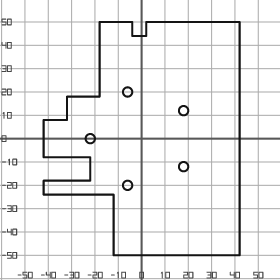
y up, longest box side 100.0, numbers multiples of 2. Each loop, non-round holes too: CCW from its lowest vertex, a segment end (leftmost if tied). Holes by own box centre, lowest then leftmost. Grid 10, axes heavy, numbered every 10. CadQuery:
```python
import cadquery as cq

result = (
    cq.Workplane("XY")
    .moveTo(-12.0, -50.0)
    .lineTo(42.0, -50.0)
    .lineTo(42.0, 50.0)
    .lineTo(2.0, 50.0)
    .lineTo(2.0, 44.0)
    .lineTo(-4.0, 44.0)
    .lineTo(-4.0, 50.0)
    .lineTo(-18.0, 50.0)
    .lineTo(-18.0, 18.0)
    .lineTo(-32.0, 18.0)
    .lineTo(-32.0, 8.0)
    .lineTo(-42.0, 8.0)
    .lineTo(-42.0, -8.0)
    .lineTo(-22.0, -8.0)
    .lineTo(-22.0, -18.0)
    .lineTo(-42.0, -18.0)
    .lineTo(-42.0, -24.0)
    .lineTo(-12.0, -24.0)
    .close()
    .moveTo(-6.0, -20.0)
    .circle(2.0)
    .moveTo(18.0, -12.0)
    .circle(2.0)
    .moveTo(-22.0, 0.0)
    .circle(2.0)
    .moveTo(18.0, 12.0)
    .circle(2.0)
    .moveTo(-6.0, 20.0)
    .circle(2.0)
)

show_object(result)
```